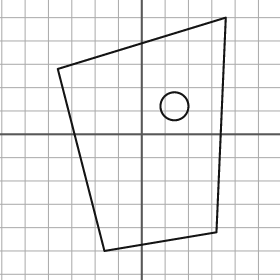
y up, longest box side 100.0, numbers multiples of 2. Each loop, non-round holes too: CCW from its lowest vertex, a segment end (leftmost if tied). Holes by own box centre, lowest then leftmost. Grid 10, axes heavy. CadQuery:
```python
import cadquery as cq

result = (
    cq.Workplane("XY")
    .moveTo(-16.0, -50.0)
    .lineTo(32.0, -42.0)
    .lineTo(36.0, 50.0)
    .lineTo(-36.0, 28.0)
    .close()
    .moveTo(14.0, 12.0)
    .circle(6.0)
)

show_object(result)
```